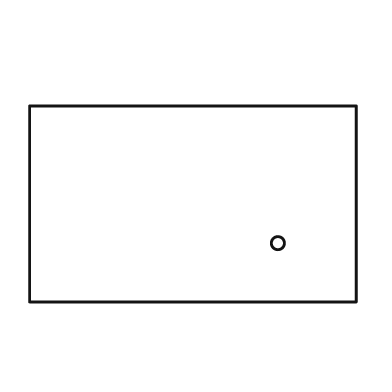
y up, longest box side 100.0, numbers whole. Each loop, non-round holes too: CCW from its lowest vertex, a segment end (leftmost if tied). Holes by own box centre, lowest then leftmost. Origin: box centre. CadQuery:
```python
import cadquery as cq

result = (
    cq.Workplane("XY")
    .moveTo(-50.0, -30.0)
    .lineTo(50.0, -30.0)
    .lineTo(50.0, 30.0)
    .lineTo(-50.0, 30.0)
    .close()
    .moveTo(26.0, -12.0)
    .circle(2.0)
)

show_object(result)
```